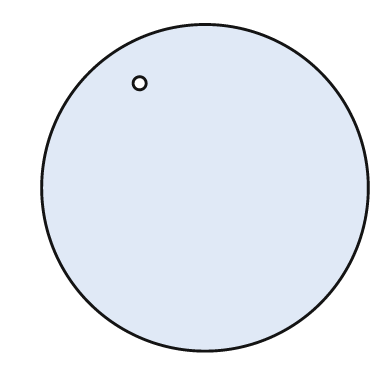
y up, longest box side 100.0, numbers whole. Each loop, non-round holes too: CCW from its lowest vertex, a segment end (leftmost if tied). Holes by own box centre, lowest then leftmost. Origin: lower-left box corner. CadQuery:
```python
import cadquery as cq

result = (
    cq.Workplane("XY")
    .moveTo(50.0, 50.0)
    .circle(50.0)
    .moveTo(30.0, 82.0)
    .circle(2.0)
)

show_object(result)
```